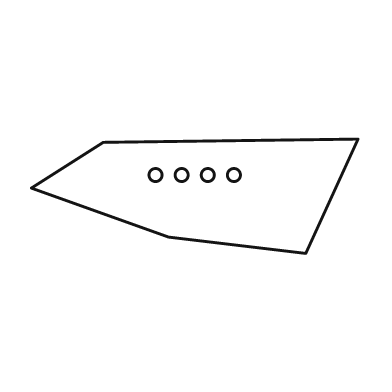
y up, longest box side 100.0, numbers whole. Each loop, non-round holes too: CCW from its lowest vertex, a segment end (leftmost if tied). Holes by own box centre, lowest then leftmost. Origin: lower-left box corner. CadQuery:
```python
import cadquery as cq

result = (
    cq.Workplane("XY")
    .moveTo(84.0, 0.0)
    .lineTo(100.0, 35.0)
    .lineTo(22.0, 34.0)
    .lineTo(0.0, 20.0)
    .lineTo(42.0, 5.0)
    .close()
    .moveTo(38.0, 24.0)
    .circle(2.0)
    .moveTo(46.0, 24.0)
    .circle(2.0)
    .moveTo(54.0, 24.0)
    .circle(2.0)
    .moveTo(62.0, 24.0)
    .circle(2.0)
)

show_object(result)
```